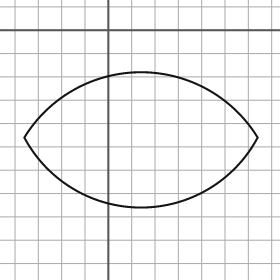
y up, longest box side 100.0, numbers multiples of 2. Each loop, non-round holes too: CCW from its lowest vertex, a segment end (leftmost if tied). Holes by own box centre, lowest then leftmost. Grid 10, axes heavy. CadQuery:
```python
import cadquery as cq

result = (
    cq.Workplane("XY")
    .moveTo(-36.0, -46.0)
    .threePointArc((14.0, -76.0), (64.0, -46.0))
    .threePointArc((14.0, -18.0), (-36.0, -46.0))
    .close()
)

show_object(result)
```